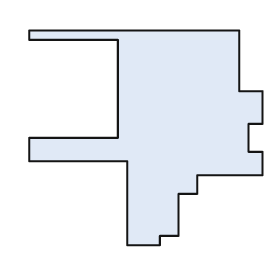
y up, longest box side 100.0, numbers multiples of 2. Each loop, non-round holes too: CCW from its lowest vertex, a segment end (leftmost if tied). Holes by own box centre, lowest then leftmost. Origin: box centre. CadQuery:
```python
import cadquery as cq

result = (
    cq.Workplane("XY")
    .moveTo(-8.0, -46.0)
    .lineTo(6.0, -46.0)
    .lineTo(6.0, -42.0)
    .lineTo(14.0, -42.0)
    .lineTo(14.0, -24.0)
    .lineTo(22.0, -24.0)
    .lineTo(22.0, -16.0)
    .lineTo(50.0, -16.0)
    .lineTo(50.0, -6.0)
    .lineTo(44.0, -6.0)
    .lineTo(44.0, 6.0)
    .lineTo(50.0, 6.0)
    .lineTo(50.0, 20.0)
    .lineTo(40.0, 20.0)
    .lineTo(40.0, 46.0)
    .lineTo(-50.0, 46.0)
    .lineTo(-50.0, 42.0)
    .lineTo(-12.0, 42.0)
    .lineTo(-12.0, 0.0)
    .lineTo(-50.0, 0.0)
    .lineTo(-50.0, -10.0)
    .lineTo(-8.0, -10.0)
    .close()
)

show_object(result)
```